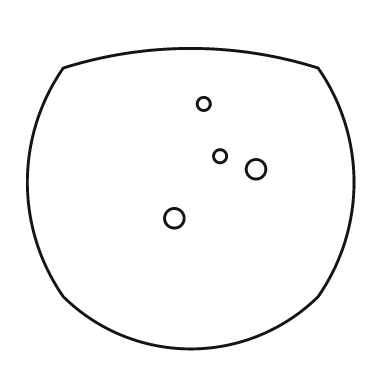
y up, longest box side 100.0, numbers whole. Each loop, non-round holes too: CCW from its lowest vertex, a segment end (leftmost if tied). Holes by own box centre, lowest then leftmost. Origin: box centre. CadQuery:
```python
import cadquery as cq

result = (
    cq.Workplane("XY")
    .moveTo(-39.0, -30.0)
    .threePointArc((0.0, -46.0), (39.0, -30.0))
    .threePointArc((50.0, 5.0), (39.0, 40.0))
    .threePointArc((0.0, 46.0), (-39.0, 40.0))
    .threePointArc((-50.0, 5.0), (-39.0, -30.0))
    .close()
    .moveTo(-5.0, -6.0)
    .circle(3.0)
    .moveTo(20.0, 9.0)
    .circle(3.0)
    .moveTo(9.0, 13.0)
    .circle(2.0)
    .moveTo(4.0, 29.0)
    .circle(2.0)
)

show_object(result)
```